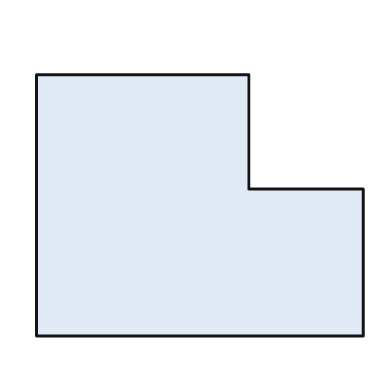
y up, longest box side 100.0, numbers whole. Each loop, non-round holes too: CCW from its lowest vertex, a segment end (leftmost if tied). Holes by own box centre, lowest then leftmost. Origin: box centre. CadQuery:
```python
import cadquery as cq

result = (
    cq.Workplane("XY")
    .moveTo(-50.0, -40.0)
    .lineTo(50.0, -40.0)
    .lineTo(50.0, 5.0)
    .lineTo(15.0, 5.0)
    .lineTo(15.0, 40.0)
    .lineTo(-50.0, 40.0)
    .close()
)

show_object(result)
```